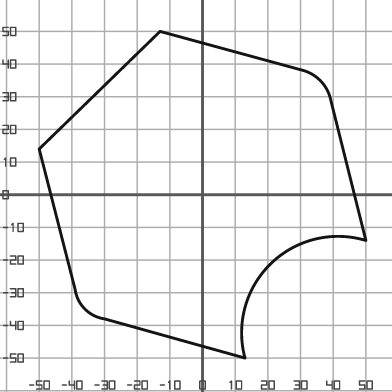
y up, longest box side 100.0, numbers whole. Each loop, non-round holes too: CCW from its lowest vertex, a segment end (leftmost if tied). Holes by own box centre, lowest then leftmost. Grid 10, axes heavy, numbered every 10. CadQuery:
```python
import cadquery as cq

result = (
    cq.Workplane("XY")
    .moveTo(13.0, -50.0)
    .threePointArc((21.0, -21.0), (50.0, -14.0))
    .lineTo(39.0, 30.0)
    .threePointArc((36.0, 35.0), (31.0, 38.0))
    .lineTo(-13.0, 50.0)
    .lineTo(-50.0, 14.0)
    .lineTo(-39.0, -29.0)
    .threePointArc((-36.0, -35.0), (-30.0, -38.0))
    .close()
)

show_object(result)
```